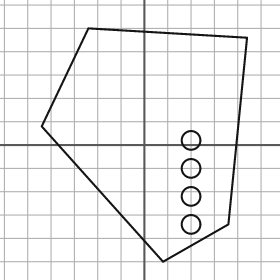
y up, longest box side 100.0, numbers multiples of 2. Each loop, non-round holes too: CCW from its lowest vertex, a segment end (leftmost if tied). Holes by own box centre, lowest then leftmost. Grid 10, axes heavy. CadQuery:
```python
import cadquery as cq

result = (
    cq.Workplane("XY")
    .moveTo(8.0, -50.0)
    .lineTo(36.0, -34.0)
    .lineTo(44.0, 46.0)
    .lineTo(-24.0, 50.0)
    .lineTo(-44.0, 8.0)
    .close()
    .moveTo(20.0, -34.0)
    .circle(4.0)
    .moveTo(20.0, -22.0)
    .circle(4.0)
    .moveTo(20.0, -10.0)
    .circle(4.0)
    .moveTo(20.0, 2.0)
    .circle(4.0)
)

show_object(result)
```